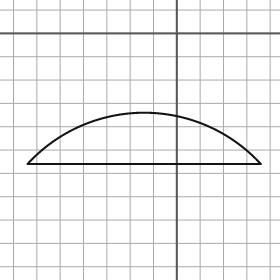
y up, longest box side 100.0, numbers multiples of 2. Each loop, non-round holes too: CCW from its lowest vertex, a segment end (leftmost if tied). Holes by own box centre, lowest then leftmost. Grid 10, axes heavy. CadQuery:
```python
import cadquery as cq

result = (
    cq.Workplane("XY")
    .moveTo(-64.0, -56.0)
    .lineTo(36.0, -56.0)
    .threePointArc((-14.0, -34.0), (-64.0, -56.0))
    .close()
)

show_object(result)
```